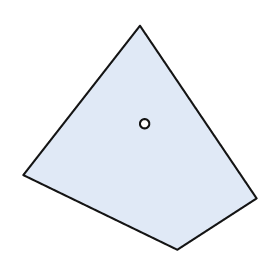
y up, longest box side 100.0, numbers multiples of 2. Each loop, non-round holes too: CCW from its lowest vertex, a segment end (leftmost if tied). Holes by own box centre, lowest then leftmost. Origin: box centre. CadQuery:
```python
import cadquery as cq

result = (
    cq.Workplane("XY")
    .moveTo(16.0, -48.0)
    .lineTo(50.0, -26.0)
    .lineTo(0.0, 48.0)
    .lineTo(-50.0, -16.0)
    .close()
    .moveTo(2.0, 6.0)
    .circle(2.0)
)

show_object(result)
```